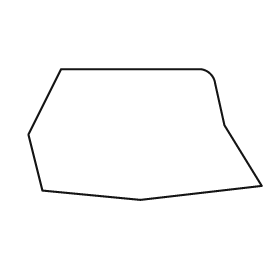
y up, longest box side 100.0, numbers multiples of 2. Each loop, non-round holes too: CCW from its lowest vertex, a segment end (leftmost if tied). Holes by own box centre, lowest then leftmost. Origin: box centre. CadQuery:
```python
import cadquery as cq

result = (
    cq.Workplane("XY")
    .moveTo(-2.0, -28.0)
    .lineTo(50.0, -22.0)
    .lineTo(34.0, 4.0)
    .lineTo(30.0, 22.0)
    .threePointArc((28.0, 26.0), (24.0, 28.0))
    .lineTo(-36.0, 28.0)
    .lineTo(-50.0, 0.0)
    .lineTo(-44.0, -24.0)
    .close()
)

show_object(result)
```